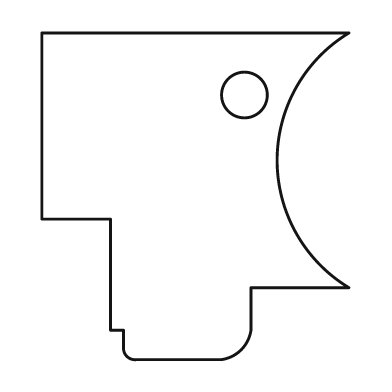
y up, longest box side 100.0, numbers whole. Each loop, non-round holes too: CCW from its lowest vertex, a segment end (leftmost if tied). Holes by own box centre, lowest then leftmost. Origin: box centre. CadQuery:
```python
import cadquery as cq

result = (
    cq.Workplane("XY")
    .moveTo(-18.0, -50.0)
    .lineTo(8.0, -50.0)
    .threePointArc((14.0, -47.0), (17.0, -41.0))
    .lineTo(17.0, -28.0)
    .lineTo(47.0, -28.0)
    .threePointArc((25.0, 11.0), (47.0, 50.0))
    .lineTo(-47.0, 50.0)
    .lineTo(-47.0, -7.0)
    .lineTo(-26.0, -7.0)
    .lineTo(-26.0, -41.0)
    .lineTo(-22.0, -41.0)
    .lineTo(-22.0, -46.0)
    .threePointArc((-21.0, -49.0), (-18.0, -50.0))
    .close()
    .moveTo(15.0, 31.0)
    .circle(7.0)
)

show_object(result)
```